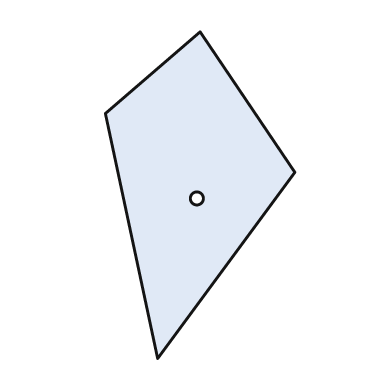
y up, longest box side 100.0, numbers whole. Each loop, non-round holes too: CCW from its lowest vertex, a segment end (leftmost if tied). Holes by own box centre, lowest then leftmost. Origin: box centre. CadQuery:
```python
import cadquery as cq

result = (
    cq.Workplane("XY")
    .moveTo(-13.0, -50.0)
    .lineTo(29.0, 7.0)
    .lineTo(0.0, 50.0)
    .lineTo(-29.0, 25.0)
    .close()
    .moveTo(-1.0, -1.0)
    .circle(2.0)
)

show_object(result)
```